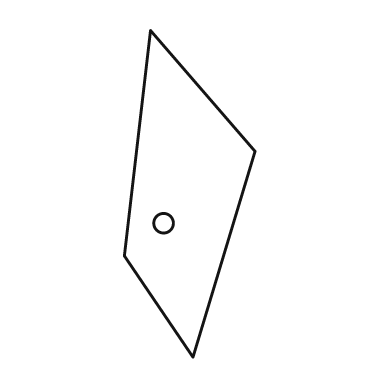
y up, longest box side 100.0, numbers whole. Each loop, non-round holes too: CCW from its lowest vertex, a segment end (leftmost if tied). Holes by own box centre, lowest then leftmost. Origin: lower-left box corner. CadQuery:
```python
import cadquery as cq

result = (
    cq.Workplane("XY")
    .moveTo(21.0, 0.0)
    .lineTo(40.0, 63.0)
    .lineTo(8.0, 100.0)
    .lineTo(0.0, 31.0)
    .close()
    .moveTo(12.0, 41.0)
    .circle(3.0)
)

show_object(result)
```